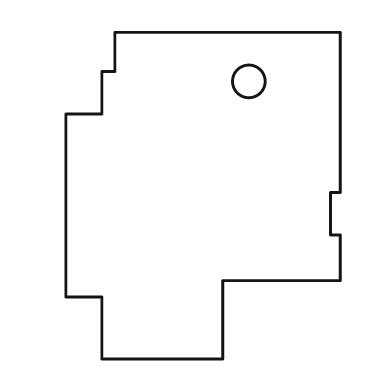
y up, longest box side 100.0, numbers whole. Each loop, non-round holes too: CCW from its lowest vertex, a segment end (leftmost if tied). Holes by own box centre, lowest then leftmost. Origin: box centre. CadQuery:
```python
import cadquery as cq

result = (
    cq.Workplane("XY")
    .moveTo(-31.0, -50.0)
    .lineTo(6.0, -50.0)
    .lineTo(6.0, -26.0)
    .lineTo(42.0, -26.0)
    .lineTo(42.0, -12.0)
    .lineTo(39.0, -12.0)
    .lineTo(39.0, 1.0)
    .lineTo(42.0, 1.0)
    .lineTo(42.0, 50.0)
    .lineTo(-27.0, 50.0)
    .lineTo(-27.0, 38.0)
    .lineTo(-31.0, 38.0)
    .lineTo(-31.0, 25.0)
    .lineTo(-42.0, 25.0)
    .lineTo(-42.0, -31.0)
    .lineTo(-31.0, -31.0)
    .close()
    .moveTo(14.0, 35.0)
    .circle(5.0)
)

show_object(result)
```